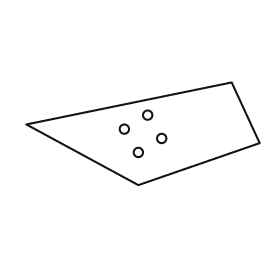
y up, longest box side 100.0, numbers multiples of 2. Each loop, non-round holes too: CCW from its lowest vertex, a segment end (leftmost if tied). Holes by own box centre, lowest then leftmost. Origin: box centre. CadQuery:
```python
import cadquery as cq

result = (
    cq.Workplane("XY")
    .moveTo(-2.0, -22.0)
    .lineTo(50.0, -4.0)
    .lineTo(38.0, 22.0)
    .lineTo(-50.0, 4.0)
    .close()
    .moveTo(-2.0, -8.0)
    .circle(2.0)
    .moveTo(8.0, -2.0)
    .circle(2.0)
    .moveTo(-8.0, 2.0)
    .circle(2.0)
    .moveTo(2.0, 8.0)
    .circle(2.0)
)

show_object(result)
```